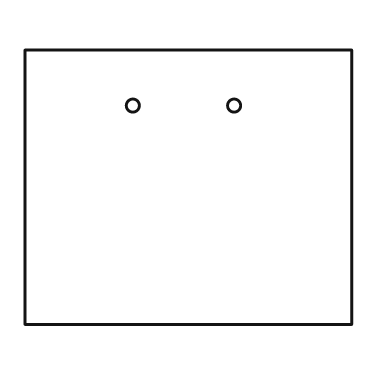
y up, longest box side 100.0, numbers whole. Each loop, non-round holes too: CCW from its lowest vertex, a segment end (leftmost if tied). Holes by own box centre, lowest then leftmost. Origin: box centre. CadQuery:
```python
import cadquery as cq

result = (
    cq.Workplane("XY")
    .moveTo(-50.0, -42.0)
    .lineTo(50.0, -42.0)
    .lineTo(50.0, 42.0)
    .lineTo(-50.0, 42.0)
    .close()
    .moveTo(-17.0, 25.0)
    .circle(2.0)
    .moveTo(14.0, 25.0)
    .circle(2.0)
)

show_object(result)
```